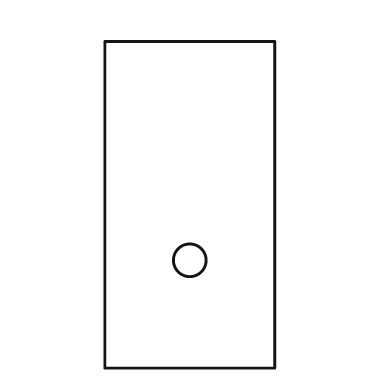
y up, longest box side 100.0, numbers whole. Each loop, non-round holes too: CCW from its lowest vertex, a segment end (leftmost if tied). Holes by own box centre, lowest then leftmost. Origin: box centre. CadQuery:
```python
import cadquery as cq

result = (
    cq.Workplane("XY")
    .moveTo(-26.0, -50.0)
    .lineTo(26.0, -50.0)
    .lineTo(26.0, 50.0)
    .lineTo(-26.0, 50.0)
    .close()
    .moveTo(0.0, -17.0)
    .circle(5.0)
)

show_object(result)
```